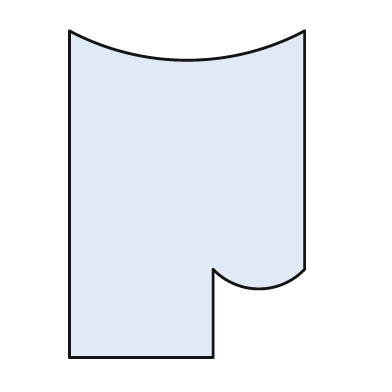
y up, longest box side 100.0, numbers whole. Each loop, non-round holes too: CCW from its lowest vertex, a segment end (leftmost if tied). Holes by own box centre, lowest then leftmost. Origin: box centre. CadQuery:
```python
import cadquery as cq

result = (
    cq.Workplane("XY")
    .moveTo(-36.0, -50.0)
    .lineTo(8.0, -50.0)
    .lineTo(8.0, -23.0)
    .threePointArc((22.0, -29.0), (36.0, -23.0))
    .lineTo(36.0, 50.0)
    .threePointArc((0.0, 41.0), (-36.0, 50.0))
    .close()
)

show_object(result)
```